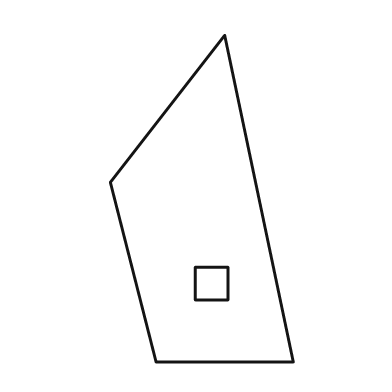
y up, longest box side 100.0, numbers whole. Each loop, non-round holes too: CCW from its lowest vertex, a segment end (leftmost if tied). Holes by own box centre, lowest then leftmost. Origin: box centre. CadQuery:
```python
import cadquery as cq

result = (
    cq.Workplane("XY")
    .moveTo(-14.0, -50.0)
    .lineTo(28.0, -50.0)
    .lineTo(7.0, 50.0)
    .lineTo(-28.0, 5.0)
    .close()
    .moveTo(-2.0, -31.0)
    .lineTo(8.0, -31.0)
    .lineTo(8.0, -21.0)
    .lineTo(-2.0, -21.0)
    .close()
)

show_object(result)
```